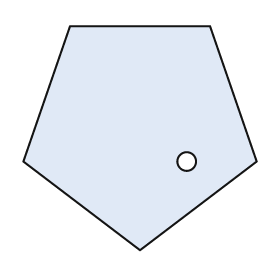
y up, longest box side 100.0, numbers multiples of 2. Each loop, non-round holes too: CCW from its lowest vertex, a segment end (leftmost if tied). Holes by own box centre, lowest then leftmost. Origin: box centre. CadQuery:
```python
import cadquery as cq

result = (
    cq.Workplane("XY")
    .moveTo(0.0, -48.0)
    .lineTo(50.0, -10.0)
    .lineTo(30.0, 48.0)
    .lineTo(-30.0, 48.0)
    .lineTo(-50.0, -10.0)
    .close()
    .moveTo(20.0, -10.0)
    .circle(4.0)
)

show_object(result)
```